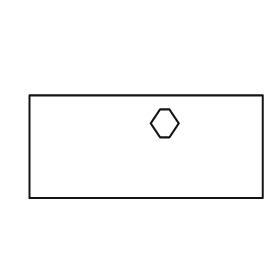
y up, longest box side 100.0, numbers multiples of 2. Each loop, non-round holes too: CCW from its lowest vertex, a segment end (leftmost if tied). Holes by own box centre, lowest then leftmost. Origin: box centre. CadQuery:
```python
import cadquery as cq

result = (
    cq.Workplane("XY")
    .moveTo(-50.0, -22.0)
    .lineTo(50.0, -22.0)
    .lineTo(50.0, 22.0)
    .lineTo(-50.0, 22.0)
    .close()
    .moveTo(6.0, 4.0)
    .lineTo(10.0, 4.0)
    .lineTo(14.0, 10.0)
    .lineTo(10.0, 16.0)
    .lineTo(6.0, 16.0)
    .lineTo(2.0, 10.0)
    .close()
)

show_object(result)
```